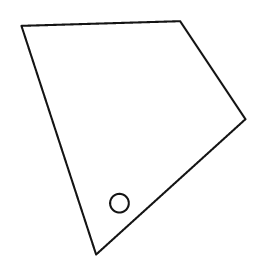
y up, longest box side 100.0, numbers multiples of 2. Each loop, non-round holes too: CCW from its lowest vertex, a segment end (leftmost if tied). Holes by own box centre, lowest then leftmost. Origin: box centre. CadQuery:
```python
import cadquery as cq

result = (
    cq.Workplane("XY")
    .moveTo(-16.0, -50.0)
    .lineTo(48.0, 8.0)
    .lineTo(20.0, 50.0)
    .lineTo(-48.0, 48.0)
    .close()
    .moveTo(-6.0, -28.0)
    .circle(4.0)
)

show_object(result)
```